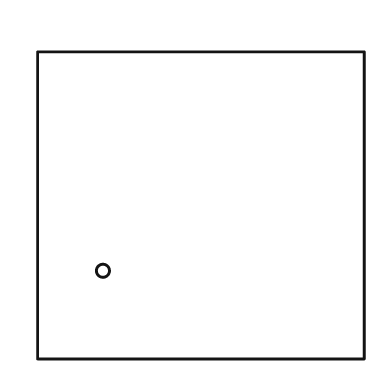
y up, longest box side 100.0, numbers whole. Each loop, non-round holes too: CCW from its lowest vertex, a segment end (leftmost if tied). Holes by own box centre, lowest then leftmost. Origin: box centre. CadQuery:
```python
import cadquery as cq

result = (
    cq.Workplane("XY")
    .moveTo(-50.0, -47.0)
    .lineTo(50.0, -47.0)
    .lineTo(50.0, 47.0)
    .lineTo(-50.0, 47.0)
    .close()
    .moveTo(-30.0, -20.0)
    .circle(2.0)
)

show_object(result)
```